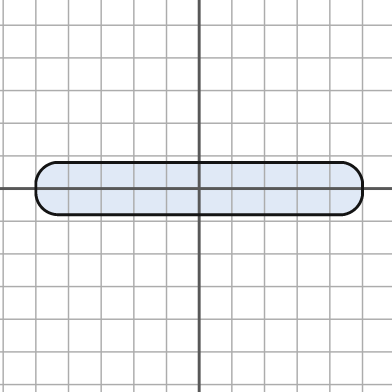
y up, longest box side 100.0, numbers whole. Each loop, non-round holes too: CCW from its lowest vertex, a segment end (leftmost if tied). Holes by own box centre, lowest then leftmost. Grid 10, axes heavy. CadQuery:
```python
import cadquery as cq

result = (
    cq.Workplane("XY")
    .moveTo(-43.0, -8.0)
    .lineTo(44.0, -8.0)
    .threePointArc((48.0, -6.0), (50.0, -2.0))
    .lineTo(50.0, 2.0)
    .threePointArc((48.0, 6.0), (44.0, 8.0))
    .lineTo(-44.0, 8.0)
    .threePointArc((-48.0, 6.0), (-50.0, 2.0))
    .lineTo(-50.0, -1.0)
    .threePointArc((-48.0, -6.0), (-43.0, -8.0))
    .close()
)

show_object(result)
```